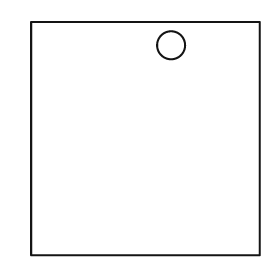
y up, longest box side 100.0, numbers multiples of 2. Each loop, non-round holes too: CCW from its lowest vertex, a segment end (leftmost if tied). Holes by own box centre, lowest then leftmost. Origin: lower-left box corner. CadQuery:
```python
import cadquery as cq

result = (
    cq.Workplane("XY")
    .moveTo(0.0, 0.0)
    .lineTo(98.0, 0.0)
    .lineTo(98.0, 100.0)
    .lineTo(0.0, 100.0)
    .close()
    .moveTo(60.0, 90.0)
    .circle(6.0)
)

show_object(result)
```